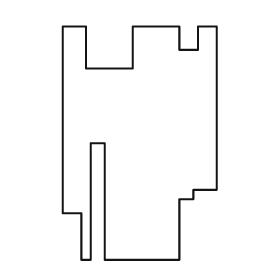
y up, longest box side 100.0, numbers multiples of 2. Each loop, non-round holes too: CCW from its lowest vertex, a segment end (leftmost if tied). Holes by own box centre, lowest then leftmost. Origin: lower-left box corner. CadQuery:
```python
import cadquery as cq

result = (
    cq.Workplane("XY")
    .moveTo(8.0, 0.0)
    .lineTo(12.0, 0.0)
    .lineTo(12.0, 50.0)
    .lineTo(18.0, 50.0)
    .lineTo(18.0, 0.0)
    .lineTo(50.0, 0.0)
    .lineTo(50.0, 26.0)
    .lineTo(56.0, 26.0)
    .lineTo(56.0, 30.0)
    .lineTo(66.0, 30.0)
    .lineTo(66.0, 100.0)
    .lineTo(58.0, 100.0)
    .lineTo(58.0, 90.0)
    .lineTo(50.0, 90.0)
    .lineTo(50.0, 100.0)
    .lineTo(30.0, 100.0)
    .lineTo(30.0, 82.0)
    .lineTo(10.0, 82.0)
    .lineTo(10.0, 100.0)
    .lineTo(0.0, 100.0)
    .lineTo(0.0, 20.0)
    .lineTo(8.0, 20.0)
    .close()
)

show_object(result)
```